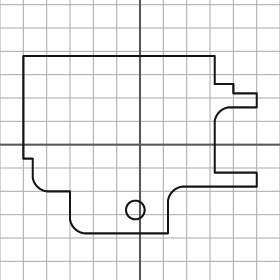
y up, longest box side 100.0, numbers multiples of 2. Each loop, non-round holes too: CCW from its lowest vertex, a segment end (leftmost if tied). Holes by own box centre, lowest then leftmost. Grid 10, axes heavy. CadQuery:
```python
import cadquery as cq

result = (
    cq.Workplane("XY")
    .moveTo(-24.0, -38.0)
    .lineTo(12.0, -38.0)
    .lineTo(12.0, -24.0)
    .threePointArc((14.0, -20.0), (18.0, -18.0))
    .lineTo(50.0, -18.0)
    .lineTo(50.0, -12.0)
    .lineTo(32.0, -12.0)
    .lineTo(32.0, 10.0)
    .threePointArc((34.0, 14.0), (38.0, 16.0))
    .lineTo(50.0, 16.0)
    .lineTo(50.0, 22.0)
    .lineTo(40.0, 22.0)
    .lineTo(40.0, 26.0)
    .lineTo(32.0, 26.0)
    .lineTo(32.0, 38.0)
    .lineTo(-50.0, 38.0)
    .lineTo(-50.0, -6.0)
    .lineTo(-46.0, -6.0)
    .lineTo(-46.0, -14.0)
    .threePointArc((-44.0, -18.0), (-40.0, -20.0))
    .lineTo(-30.0, -20.0)
    .lineTo(-30.0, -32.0)
    .threePointArc((-28.0, -36.0), (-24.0, -38.0))
    .close()
    .moveTo(-2.0, -28.0)
    .circle(4.0)
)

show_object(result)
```